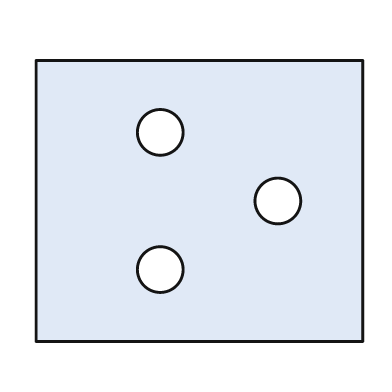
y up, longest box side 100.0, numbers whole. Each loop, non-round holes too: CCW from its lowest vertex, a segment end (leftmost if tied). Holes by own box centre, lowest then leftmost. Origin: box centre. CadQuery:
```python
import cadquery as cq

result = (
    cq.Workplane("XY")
    .moveTo(-50.0, -43.0)
    .lineTo(50.0, -43.0)
    .lineTo(50.0, 43.0)
    .lineTo(-50.0, 43.0)
    .close()
    .moveTo(-12.0, -21.0)
    .circle(7.0)
    .moveTo(24.0, 0.0)
    .circle(7.0)
    .moveTo(-12.0, 21.0)
    .circle(7.0)
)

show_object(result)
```